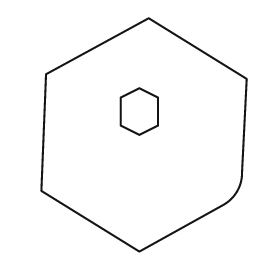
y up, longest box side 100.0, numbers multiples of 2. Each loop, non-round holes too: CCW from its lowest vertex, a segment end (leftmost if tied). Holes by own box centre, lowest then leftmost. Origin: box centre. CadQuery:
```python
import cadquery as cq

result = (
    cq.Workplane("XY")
    .moveTo(-2.0, -50.0)
    .lineTo(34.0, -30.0)
    .threePointArc((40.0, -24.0), (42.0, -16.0))
    .lineTo(44.0, 24.0)
    .lineTo(2.0, 50.0)
    .lineTo(-42.0, 26.0)
    .lineTo(-44.0, -24.0)
    .close()
    .moveTo(-2.0, 0.0)
    .lineTo(6.0, 4.0)
    .lineTo(6.0, 16.0)
    .lineTo(-2.0, 20.0)
    .lineTo(-10.0, 16.0)
    .lineTo(-10.0, 4.0)
    .close()
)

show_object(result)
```